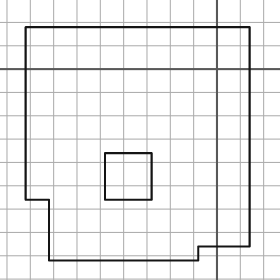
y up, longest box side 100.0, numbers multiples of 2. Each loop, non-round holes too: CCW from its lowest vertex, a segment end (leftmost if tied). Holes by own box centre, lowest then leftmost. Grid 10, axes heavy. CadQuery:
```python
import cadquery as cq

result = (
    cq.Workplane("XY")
    .moveTo(-72.0, -82.0)
    .lineTo(-8.0, -82.0)
    .lineTo(-8.0, -76.0)
    .lineTo(14.0, -76.0)
    .lineTo(14.0, 18.0)
    .lineTo(-82.0, 18.0)
    .lineTo(-82.0, -56.0)
    .lineTo(-72.0, -56.0)
    .close()
    .moveTo(-48.0, -56.0)
    .lineTo(-28.0, -56.0)
    .lineTo(-28.0, -36.0)
    .lineTo(-48.0, -36.0)
    .close()
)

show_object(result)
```